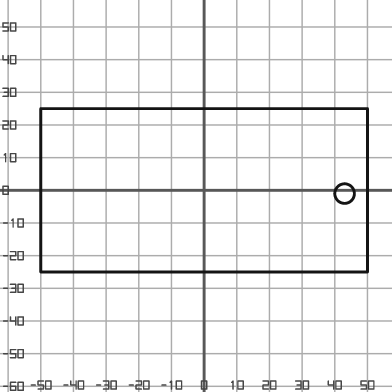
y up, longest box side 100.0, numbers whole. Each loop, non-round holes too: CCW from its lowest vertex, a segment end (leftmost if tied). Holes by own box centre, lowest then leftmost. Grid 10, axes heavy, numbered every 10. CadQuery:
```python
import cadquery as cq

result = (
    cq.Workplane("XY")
    .moveTo(-50.0, -25.0)
    .lineTo(50.0, -25.0)
    .lineTo(50.0, 25.0)
    .lineTo(-50.0, 25.0)
    .close()
    .moveTo(43.0, -1.0)
    .circle(3.0)
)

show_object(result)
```